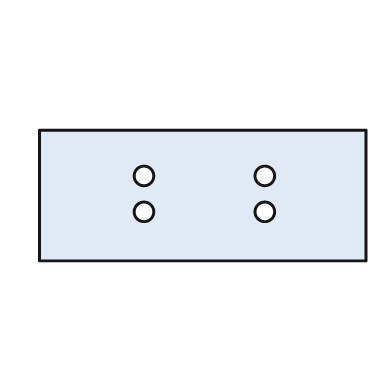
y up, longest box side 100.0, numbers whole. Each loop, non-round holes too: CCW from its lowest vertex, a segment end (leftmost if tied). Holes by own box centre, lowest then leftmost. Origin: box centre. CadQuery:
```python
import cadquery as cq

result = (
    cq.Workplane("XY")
    .moveTo(-50.0, -20.0)
    .lineTo(50.0, -20.0)
    .lineTo(50.0, 20.0)
    .lineTo(-50.0, 20.0)
    .close()
    .moveTo(-18.0, -5.0)
    .circle(3.0)
    .moveTo(19.0, -5.0)
    .circle(3.0)
    .moveTo(-18.0, 6.0)
    .circle(3.0)
    .moveTo(19.0, 6.0)
    .circle(3.0)
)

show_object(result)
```